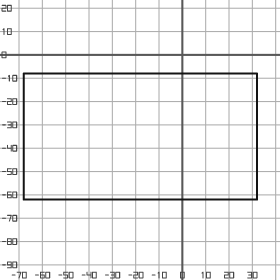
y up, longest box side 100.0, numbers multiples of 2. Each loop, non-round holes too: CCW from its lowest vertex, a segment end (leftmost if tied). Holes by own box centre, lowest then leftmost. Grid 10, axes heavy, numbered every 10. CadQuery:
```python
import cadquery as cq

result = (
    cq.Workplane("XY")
    .moveTo(-68.0, -62.0)
    .lineTo(32.0, -62.0)
    .lineTo(32.0, -8.0)
    .lineTo(-68.0, -8.0)
    .close()
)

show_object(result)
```